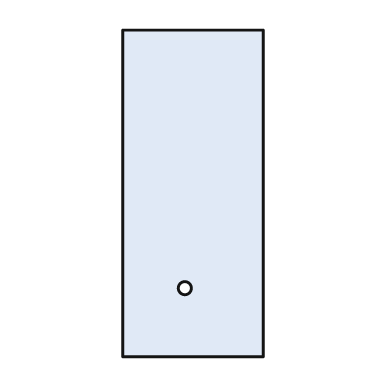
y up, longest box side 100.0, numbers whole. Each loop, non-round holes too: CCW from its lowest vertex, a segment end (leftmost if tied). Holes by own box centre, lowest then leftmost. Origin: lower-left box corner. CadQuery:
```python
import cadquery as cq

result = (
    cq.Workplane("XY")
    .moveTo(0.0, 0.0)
    .lineTo(43.0, 0.0)
    .lineTo(43.0, 100.0)
    .lineTo(0.0, 100.0)
    .close()
    .moveTo(19.0, 21.0)
    .circle(2.0)
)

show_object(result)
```